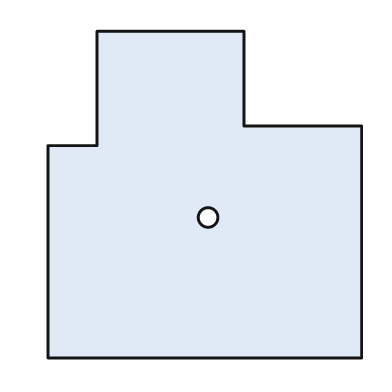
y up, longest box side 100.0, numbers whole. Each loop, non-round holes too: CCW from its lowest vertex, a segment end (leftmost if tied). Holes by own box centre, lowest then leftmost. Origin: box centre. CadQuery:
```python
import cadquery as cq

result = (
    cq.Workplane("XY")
    .moveTo(-48.0, -50.0)
    .lineTo(48.0, -50.0)
    .lineTo(48.0, 21.0)
    .lineTo(12.0, 21.0)
    .lineTo(12.0, 50.0)
    .lineTo(-33.0, 50.0)
    .lineTo(-33.0, 15.0)
    .lineTo(-48.0, 15.0)
    .close()
    .moveTo(1.0, -7.0)
    .circle(3.0)
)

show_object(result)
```